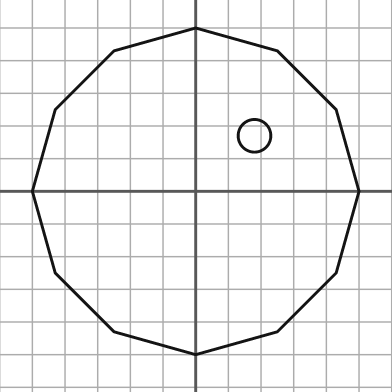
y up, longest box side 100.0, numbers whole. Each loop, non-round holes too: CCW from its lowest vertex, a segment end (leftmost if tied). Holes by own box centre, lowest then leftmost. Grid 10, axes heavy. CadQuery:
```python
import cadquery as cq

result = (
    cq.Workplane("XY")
    .moveTo(0.0, -50.0)
    .lineTo(25.0, -43.0)
    .lineTo(43.0, -25.0)
    .lineTo(50.0, 0.0)
    .lineTo(43.0, 25.0)
    .lineTo(25.0, 43.0)
    .lineTo(0.0, 50.0)
    .lineTo(-25.0, 43.0)
    .lineTo(-43.0, 25.0)
    .lineTo(-50.0, 0.0)
    .lineTo(-43.0, -25.0)
    .lineTo(-25.0, -43.0)
    .close()
    .moveTo(18.0, 17.0)
    .circle(5.0)
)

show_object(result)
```